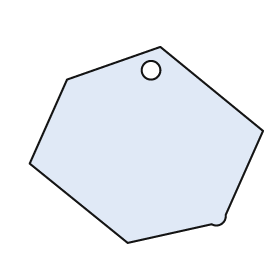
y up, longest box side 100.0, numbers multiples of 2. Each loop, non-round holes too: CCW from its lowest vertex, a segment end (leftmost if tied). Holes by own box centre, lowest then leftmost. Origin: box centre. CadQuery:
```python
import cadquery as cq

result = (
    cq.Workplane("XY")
    .moveTo(-8.0, -42.0)
    .lineTo(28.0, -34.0)
    .threePointArc((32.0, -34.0), (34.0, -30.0))
    .lineTo(50.0, 6.0)
    .lineTo(6.0, 42.0)
    .lineTo(-34.0, 28.0)
    .lineTo(-50.0, -8.0)
    .close()
    .moveTo(2.0, 32.0)
    .circle(4.0)
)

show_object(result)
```